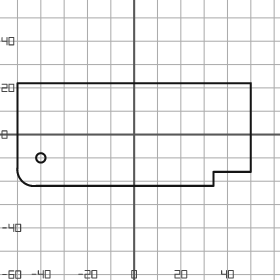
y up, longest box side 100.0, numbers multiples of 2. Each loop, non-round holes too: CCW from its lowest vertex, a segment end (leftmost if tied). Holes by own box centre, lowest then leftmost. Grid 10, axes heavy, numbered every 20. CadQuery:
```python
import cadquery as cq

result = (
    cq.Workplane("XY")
    .moveTo(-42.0, -22.0)
    .lineTo(34.0, -22.0)
    .lineTo(34.0, -16.0)
    .lineTo(50.0, -16.0)
    .lineTo(50.0, 22.0)
    .lineTo(-50.0, 22.0)
    .lineTo(-50.0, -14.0)
    .threePointArc((-48.0, -20.0), (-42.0, -22.0))
    .close()
    .moveTo(-40.0, -10.0)
    .circle(2.0)
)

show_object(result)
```